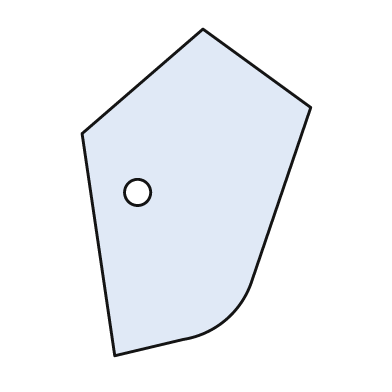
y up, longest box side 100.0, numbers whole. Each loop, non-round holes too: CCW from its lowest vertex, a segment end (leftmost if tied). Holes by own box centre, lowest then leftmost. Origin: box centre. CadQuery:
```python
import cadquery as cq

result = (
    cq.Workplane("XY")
    .moveTo(-25.0, -50.0)
    .lineTo(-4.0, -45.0)
    .threePointArc((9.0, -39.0), (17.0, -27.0))
    .lineTo(35.0, 26.0)
    .lineTo(2.0, 50.0)
    .lineTo(-35.0, 18.0)
    .close()
    .moveTo(-18.0, 0.0)
    .circle(4.0)
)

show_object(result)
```